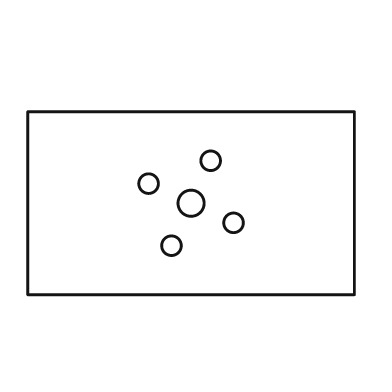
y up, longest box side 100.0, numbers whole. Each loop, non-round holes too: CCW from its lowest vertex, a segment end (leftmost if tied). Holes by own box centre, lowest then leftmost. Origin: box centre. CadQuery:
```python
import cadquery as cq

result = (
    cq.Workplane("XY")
    .moveTo(-50.0, -28.0)
    .lineTo(50.0, -28.0)
    .lineTo(50.0, 28.0)
    .lineTo(-50.0, 28.0)
    .close()
    .moveTo(-6.0, -13.0)
    .circle(3.0)
    .moveTo(13.0, -6.0)
    .circle(3.0)
    .moveTo(0.0, 0.0)
    .circle(4.0)
    .moveTo(-13.0, 6.0)
    .circle(3.0)
    .moveTo(6.0, 13.0)
    .circle(3.0)
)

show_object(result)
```